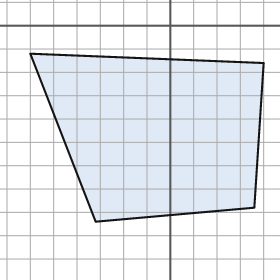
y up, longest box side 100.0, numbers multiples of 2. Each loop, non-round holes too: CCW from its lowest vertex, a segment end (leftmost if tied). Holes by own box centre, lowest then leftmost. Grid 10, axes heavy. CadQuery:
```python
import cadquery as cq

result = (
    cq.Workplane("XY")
    .moveTo(-32.0, -84.0)
    .lineTo(36.0, -78.0)
    .lineTo(40.0, -16.0)
    .lineTo(-60.0, -12.0)
    .close()
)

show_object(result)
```